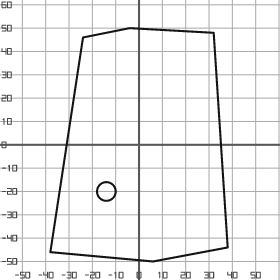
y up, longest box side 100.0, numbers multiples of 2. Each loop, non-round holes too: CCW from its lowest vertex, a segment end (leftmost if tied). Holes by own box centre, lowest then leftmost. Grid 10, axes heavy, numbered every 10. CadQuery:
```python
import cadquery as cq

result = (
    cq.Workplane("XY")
    .moveTo(6.0, -50.0)
    .lineTo(38.0, -44.0)
    .lineTo(32.0, 48.0)
    .lineTo(-4.0, 50.0)
    .lineTo(-24.0, 46.0)
    .lineTo(-38.0, -46.0)
    .close()
    .moveTo(-14.0, -20.0)
    .circle(4.0)
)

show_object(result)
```